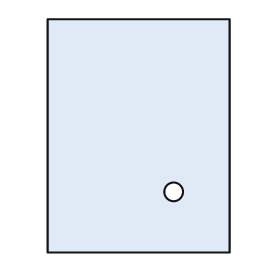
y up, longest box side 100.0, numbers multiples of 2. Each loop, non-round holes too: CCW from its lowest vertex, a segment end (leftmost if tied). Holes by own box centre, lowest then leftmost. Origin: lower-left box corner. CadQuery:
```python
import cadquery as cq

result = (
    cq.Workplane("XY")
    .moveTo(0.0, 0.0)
    .lineTo(78.0, 0.0)
    .lineTo(78.0, 100.0)
    .lineTo(0.0, 100.0)
    .close()
    .moveTo(54.0, 26.0)
    .circle(4.0)
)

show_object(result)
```